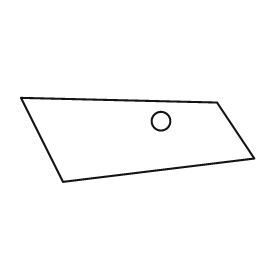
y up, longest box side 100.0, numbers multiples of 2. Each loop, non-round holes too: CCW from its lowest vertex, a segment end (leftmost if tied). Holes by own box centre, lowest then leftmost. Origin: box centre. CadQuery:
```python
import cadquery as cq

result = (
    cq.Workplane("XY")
    .moveTo(-32.0, -18.0)
    .lineTo(50.0, -8.0)
    .lineTo(34.0, 16.0)
    .lineTo(-50.0, 18.0)
    .close()
    .moveTo(10.0, 8.0)
    .circle(4.0)
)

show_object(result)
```